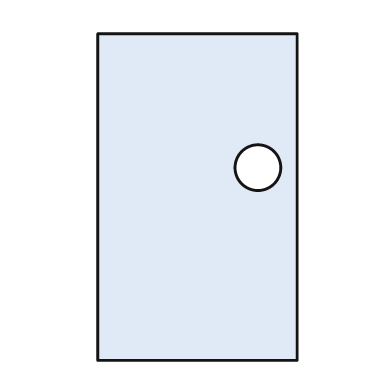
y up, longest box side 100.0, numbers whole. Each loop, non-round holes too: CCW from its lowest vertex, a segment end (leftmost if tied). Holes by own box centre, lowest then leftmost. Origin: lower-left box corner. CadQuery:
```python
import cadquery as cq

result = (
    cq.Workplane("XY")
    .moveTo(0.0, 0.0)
    .lineTo(61.0, 0.0)
    .lineTo(61.0, 100.0)
    .lineTo(0.0, 100.0)
    .close()
    .moveTo(49.0, 59.0)
    .circle(7.0)
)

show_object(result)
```